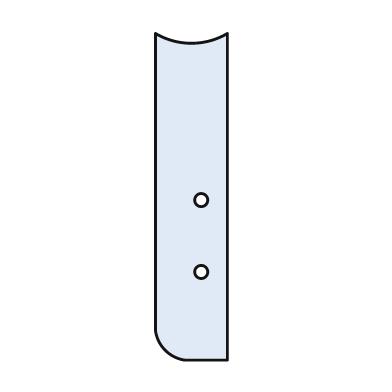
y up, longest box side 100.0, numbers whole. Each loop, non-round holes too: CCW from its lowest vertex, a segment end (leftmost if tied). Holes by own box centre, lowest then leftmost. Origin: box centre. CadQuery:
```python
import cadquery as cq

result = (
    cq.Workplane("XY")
    .moveTo(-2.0, -50.0)
    .lineTo(11.0, -50.0)
    .lineTo(11.0, 50.0)
    .threePointArc((0.0, 47.0), (-11.0, 50.0))
    .lineTo(-11.0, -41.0)
    .threePointArc((-8.0, -47.0), (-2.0, -50.0))
    .close()
    .moveTo(3.0, -23.0)
    .circle(2.0)
    .moveTo(3.0, -1.0)
    .circle(2.0)
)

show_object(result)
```